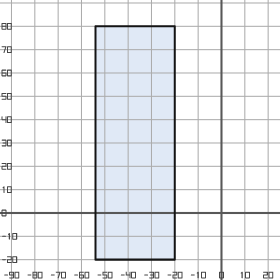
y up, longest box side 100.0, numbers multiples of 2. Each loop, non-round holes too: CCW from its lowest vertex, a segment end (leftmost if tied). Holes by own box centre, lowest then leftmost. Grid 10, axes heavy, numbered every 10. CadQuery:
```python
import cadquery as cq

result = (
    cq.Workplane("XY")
    .moveTo(-54.0, -20.0)
    .lineTo(-20.0, -20.0)
    .lineTo(-20.0, 80.0)
    .lineTo(-54.0, 80.0)
    .close()
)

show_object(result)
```